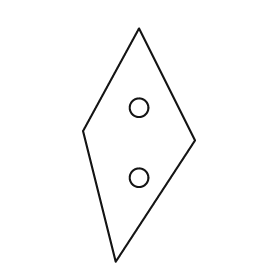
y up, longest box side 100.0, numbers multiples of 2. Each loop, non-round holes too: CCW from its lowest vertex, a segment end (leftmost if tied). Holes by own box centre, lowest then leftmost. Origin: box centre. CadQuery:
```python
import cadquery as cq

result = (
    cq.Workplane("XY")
    .moveTo(-10.0, -50.0)
    .lineTo(24.0, 2.0)
    .lineTo(0.0, 50.0)
    .lineTo(-24.0, 6.0)
    .close()
    .moveTo(0.0, -14.0)
    .circle(4.0)
    .moveTo(0.0, 16.0)
    .circle(4.0)
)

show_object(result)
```